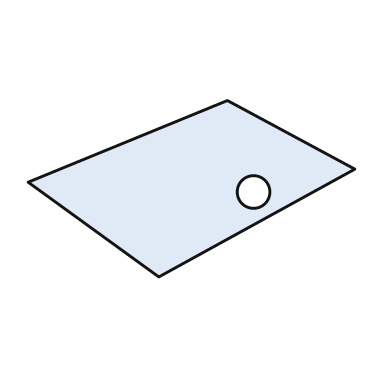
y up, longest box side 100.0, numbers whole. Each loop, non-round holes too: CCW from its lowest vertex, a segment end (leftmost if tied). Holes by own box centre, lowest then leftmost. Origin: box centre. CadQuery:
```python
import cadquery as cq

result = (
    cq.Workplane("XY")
    .moveTo(-10.0, -27.0)
    .lineTo(50.0, 6.0)
    .lineTo(11.0, 27.0)
    .lineTo(-50.0, 2.0)
    .close()
    .moveTo(19.0, -1.0)
    .circle(5.0)
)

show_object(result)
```